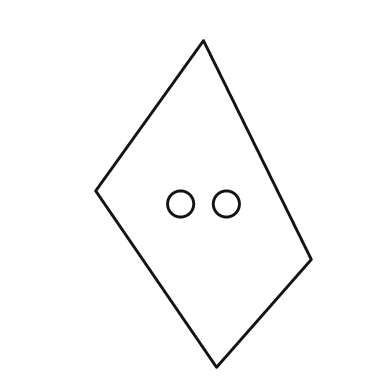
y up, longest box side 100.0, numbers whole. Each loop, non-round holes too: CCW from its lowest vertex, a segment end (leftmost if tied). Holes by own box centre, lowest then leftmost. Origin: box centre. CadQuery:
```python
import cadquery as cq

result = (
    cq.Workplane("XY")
    .moveTo(4.0, -50.0)
    .lineTo(33.0, -17.0)
    .lineTo(0.0, 50.0)
    .lineTo(-33.0, 4.0)
    .close()
    .moveTo(-7.0, 0.0)
    .circle(4.0)
    .moveTo(7.0, 0.0)
    .circle(4.0)
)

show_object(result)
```